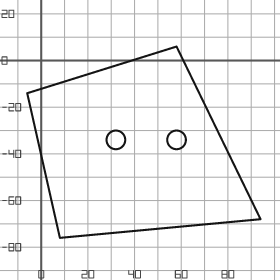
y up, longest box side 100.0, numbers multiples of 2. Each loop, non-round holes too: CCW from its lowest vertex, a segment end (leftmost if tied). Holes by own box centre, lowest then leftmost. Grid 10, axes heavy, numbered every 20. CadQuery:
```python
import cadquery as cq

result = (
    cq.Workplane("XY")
    .moveTo(8.0, -76.0)
    .lineTo(94.0, -68.0)
    .lineTo(58.0, 6.0)
    .lineTo(-6.0, -14.0)
    .close()
    .moveTo(32.0, -34.0)
    .circle(4.0)
    .moveTo(58.0, -34.0)
    .circle(4.0)
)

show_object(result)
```